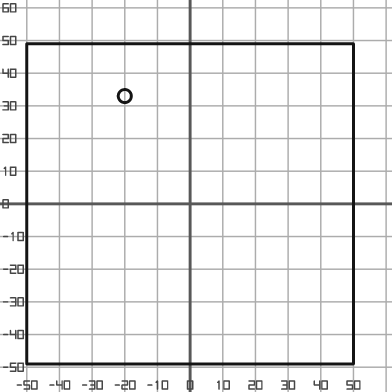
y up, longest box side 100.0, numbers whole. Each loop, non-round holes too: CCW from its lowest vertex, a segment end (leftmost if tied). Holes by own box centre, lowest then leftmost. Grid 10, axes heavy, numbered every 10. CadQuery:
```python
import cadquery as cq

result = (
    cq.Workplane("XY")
    .moveTo(-50.0, -49.0)
    .lineTo(50.0, -49.0)
    .lineTo(50.0, 49.0)
    .lineTo(-50.0, 49.0)
    .close()
    .moveTo(-20.0, 33.0)
    .circle(2.0)
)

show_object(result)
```